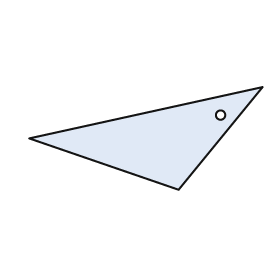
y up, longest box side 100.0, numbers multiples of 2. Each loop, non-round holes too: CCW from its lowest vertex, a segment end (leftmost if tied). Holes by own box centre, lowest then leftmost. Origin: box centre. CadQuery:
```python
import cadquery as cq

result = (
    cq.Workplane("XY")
    .moveTo(14.0, -22.0)
    .lineTo(50.0, 22.0)
    .lineTo(-50.0, 0.0)
    .close()
    .moveTo(32.0, 10.0)
    .circle(2.0)
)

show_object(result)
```